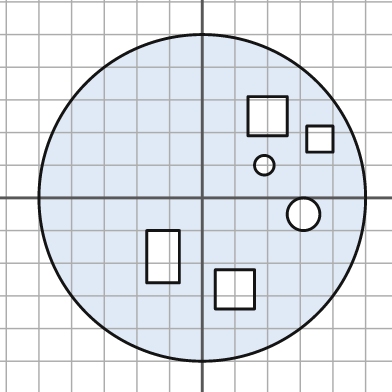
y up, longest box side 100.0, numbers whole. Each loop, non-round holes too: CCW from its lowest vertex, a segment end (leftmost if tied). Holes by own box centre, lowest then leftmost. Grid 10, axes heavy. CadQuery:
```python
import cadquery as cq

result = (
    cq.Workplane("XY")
    .moveTo(0.0, 0.0)
    .circle(50.0)
    .moveTo(4.0, -34.0)
    .lineTo(16.0, -34.0)
    .lineTo(16.0, -22.0)
    .lineTo(4.0, -22.0)
    .close()
    .moveTo(-17.0, -26.0)
    .lineTo(-7.0, -26.0)
    .lineTo(-7.0, -10.0)
    .lineTo(-17.0, -10.0)
    .close()
    .moveTo(31.0, -5.0)
    .circle(5.0)
    .moveTo(19.0, 10.0)
    .circle(3.0)
    .moveTo(32.0, 14.0)
    .lineTo(40.0, 14.0)
    .lineTo(40.0, 22.0)
    .lineTo(32.0, 22.0)
    .close()
    .moveTo(14.0, 19.0)
    .lineTo(26.0, 19.0)
    .lineTo(26.0, 31.0)
    .lineTo(14.0, 31.0)
    .close()
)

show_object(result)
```